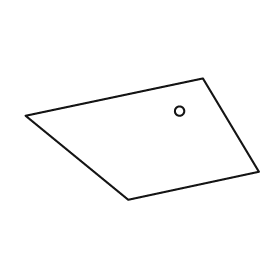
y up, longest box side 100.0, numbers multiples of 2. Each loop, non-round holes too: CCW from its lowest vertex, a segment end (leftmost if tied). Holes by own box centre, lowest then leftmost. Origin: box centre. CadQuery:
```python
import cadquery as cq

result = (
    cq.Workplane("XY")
    .moveTo(-6.0, -26.0)
    .lineTo(50.0, -14.0)
    .lineTo(26.0, 26.0)
    .lineTo(-50.0, 10.0)
    .close()
    .moveTo(16.0, 12.0)
    .circle(2.0)
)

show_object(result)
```